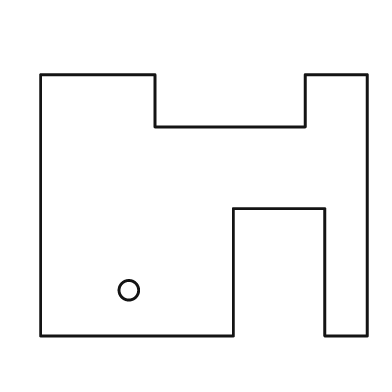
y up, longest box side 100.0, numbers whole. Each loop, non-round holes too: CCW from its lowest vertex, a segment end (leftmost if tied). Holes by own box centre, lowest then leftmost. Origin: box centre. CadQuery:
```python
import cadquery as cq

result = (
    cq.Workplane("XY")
    .moveTo(-50.0, -40.0)
    .lineTo(9.0, -40.0)
    .lineTo(9.0, -1.0)
    .lineTo(37.0, -1.0)
    .lineTo(37.0, -40.0)
    .lineTo(50.0, -40.0)
    .lineTo(50.0, 40.0)
    .lineTo(31.0, 40.0)
    .lineTo(31.0, 24.0)
    .lineTo(-15.0, 24.0)
    .lineTo(-15.0, 40.0)
    .lineTo(-50.0, 40.0)
    .close()
    .moveTo(-23.0, -26.0)
    .circle(3.0)
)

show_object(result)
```